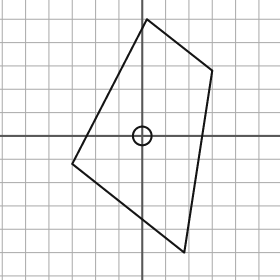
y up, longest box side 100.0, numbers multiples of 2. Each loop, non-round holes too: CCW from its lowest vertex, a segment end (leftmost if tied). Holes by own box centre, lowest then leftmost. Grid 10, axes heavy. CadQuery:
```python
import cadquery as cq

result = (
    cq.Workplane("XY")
    .moveTo(18.0, -50.0)
    .lineTo(30.0, 28.0)
    .lineTo(2.0, 50.0)
    .lineTo(-30.0, -12.0)
    .close()
    .moveTo(0.0, 0.0)
    .circle(4.0)
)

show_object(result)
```